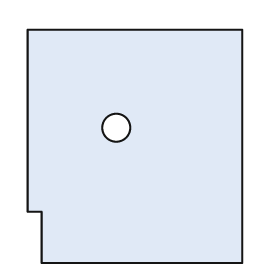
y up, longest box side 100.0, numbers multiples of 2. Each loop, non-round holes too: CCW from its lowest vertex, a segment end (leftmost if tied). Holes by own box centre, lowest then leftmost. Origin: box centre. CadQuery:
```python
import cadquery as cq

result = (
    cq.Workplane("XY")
    .moveTo(-40.0, -50.0)
    .lineTo(46.0, -50.0)
    .lineTo(46.0, 50.0)
    .lineTo(-46.0, 50.0)
    .lineTo(-46.0, -28.0)
    .lineTo(-40.0, -28.0)
    .close()
    .moveTo(-8.0, 8.0)
    .circle(6.0)
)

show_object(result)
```